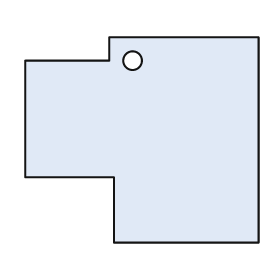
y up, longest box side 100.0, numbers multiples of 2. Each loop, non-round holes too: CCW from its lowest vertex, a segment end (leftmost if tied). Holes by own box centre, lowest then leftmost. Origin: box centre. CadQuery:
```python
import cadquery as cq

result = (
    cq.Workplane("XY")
    .moveTo(-12.0, -44.0)
    .lineTo(50.0, -44.0)
    .lineTo(50.0, 44.0)
    .lineTo(-14.0, 44.0)
    .lineTo(-14.0, 34.0)
    .lineTo(-50.0, 34.0)
    .lineTo(-50.0, -16.0)
    .lineTo(-12.0, -16.0)
    .close()
    .moveTo(-4.0, 34.0)
    .circle(4.0)
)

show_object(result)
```